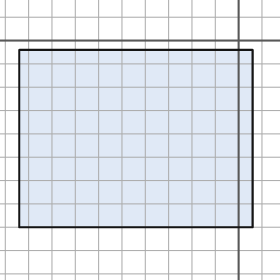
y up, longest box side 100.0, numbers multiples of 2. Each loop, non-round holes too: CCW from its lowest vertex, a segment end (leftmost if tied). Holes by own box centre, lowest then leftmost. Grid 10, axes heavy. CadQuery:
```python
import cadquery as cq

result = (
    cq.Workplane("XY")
    .moveTo(-94.0, -80.0)
    .lineTo(6.0, -80.0)
    .lineTo(6.0, -4.0)
    .lineTo(-94.0, -4.0)
    .close()
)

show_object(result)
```